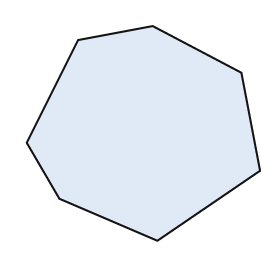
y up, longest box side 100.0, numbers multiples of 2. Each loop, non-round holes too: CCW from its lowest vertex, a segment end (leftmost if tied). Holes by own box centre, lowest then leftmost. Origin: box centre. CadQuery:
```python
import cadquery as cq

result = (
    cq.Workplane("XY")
    .moveTo(6.0, -46.0)
    .lineTo(50.0, -16.0)
    .lineTo(42.0, 26.0)
    .lineTo(4.0, 46.0)
    .lineTo(-28.0, 40.0)
    .lineTo(-50.0, -4.0)
    .lineTo(-36.0, -28.0)
    .close()
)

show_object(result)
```